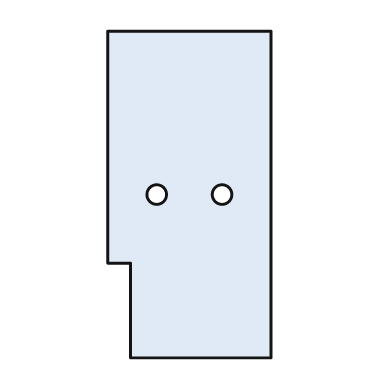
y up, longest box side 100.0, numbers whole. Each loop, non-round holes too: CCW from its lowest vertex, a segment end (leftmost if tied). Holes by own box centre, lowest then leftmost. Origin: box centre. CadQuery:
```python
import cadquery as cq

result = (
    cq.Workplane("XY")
    .moveTo(-18.0, -50.0)
    .lineTo(25.0, -50.0)
    .lineTo(25.0, 50.0)
    .lineTo(-25.0, 50.0)
    .lineTo(-25.0, -21.0)
    .lineTo(-18.0, -21.0)
    .close()
    .moveTo(-10.0, 0.0)
    .circle(3.0)
    .moveTo(10.0, 0.0)
    .circle(3.0)
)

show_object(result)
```